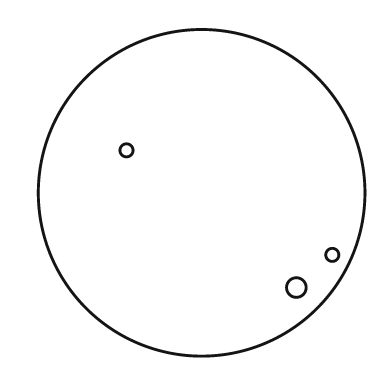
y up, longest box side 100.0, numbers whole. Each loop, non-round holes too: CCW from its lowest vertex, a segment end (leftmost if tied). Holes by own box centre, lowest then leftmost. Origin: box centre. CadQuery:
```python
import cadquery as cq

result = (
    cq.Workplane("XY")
    .moveTo(0.0, 0.0)
    .circle(50.0)
    .moveTo(29.0, -29.0)
    .circle(3.0)
    .moveTo(40.0, -19.0)
    .circle(2.0)
    .moveTo(-23.0, 13.0)
    .circle(2.0)
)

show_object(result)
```